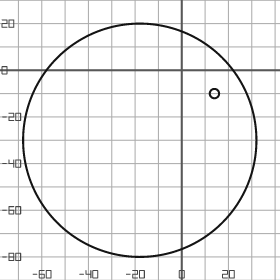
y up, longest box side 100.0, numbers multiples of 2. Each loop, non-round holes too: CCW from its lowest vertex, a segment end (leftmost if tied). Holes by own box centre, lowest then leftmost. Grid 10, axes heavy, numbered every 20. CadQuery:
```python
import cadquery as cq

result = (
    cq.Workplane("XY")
    .moveTo(-18.0, -30.0)
    .circle(50.0)
    .moveTo(14.0, -10.0)
    .circle(2.0)
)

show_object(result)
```